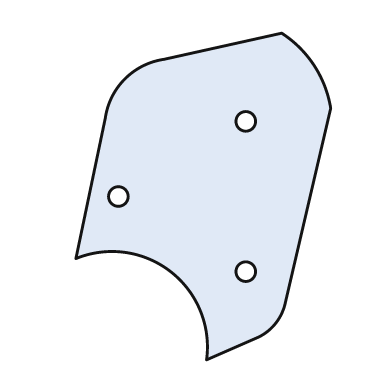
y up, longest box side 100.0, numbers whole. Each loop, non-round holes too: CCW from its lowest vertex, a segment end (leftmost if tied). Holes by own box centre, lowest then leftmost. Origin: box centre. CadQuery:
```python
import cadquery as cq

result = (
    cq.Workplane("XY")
    .moveTo(1.0, -50.0)
    .lineTo(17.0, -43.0)
    .threePointArc((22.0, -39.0), (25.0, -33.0))
    .lineTo(39.0, 27.0)
    .threePointArc((34.0, 40.0), (24.0, 50.0))
    .lineTo(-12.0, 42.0)
    .threePointArc((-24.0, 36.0), (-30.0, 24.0))
    .lineTo(-39.0, -19.0)
    .threePointArc((-10.0, -23.0), (1.0, -50.0))
    .close()
    .moveTo(13.0, -23.0)
    .circle(3.0)
    .moveTo(-26.0, 0.0)
    .circle(3.0)
    .moveTo(13.0, 23.0)
    .circle(3.0)
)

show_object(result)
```